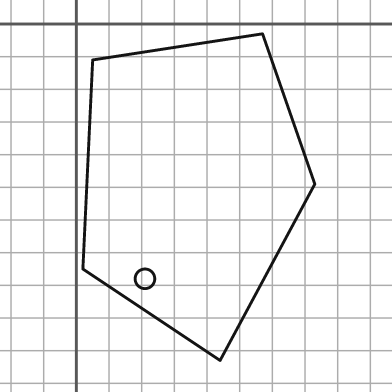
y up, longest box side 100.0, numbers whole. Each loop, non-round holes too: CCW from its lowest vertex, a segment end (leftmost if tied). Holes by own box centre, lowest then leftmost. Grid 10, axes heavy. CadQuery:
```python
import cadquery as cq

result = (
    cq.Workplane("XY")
    .moveTo(44.0, -103.0)
    .lineTo(73.0, -49.0)
    .lineTo(57.0, -3.0)
    .lineTo(5.0, -11.0)
    .lineTo(2.0, -75.0)
    .close()
    .moveTo(21.0, -78.0)
    .circle(3.0)
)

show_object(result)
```